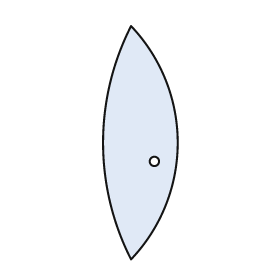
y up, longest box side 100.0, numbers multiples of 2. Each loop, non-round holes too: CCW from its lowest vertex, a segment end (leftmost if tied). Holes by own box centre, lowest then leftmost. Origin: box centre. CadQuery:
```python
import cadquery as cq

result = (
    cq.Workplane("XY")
    .moveTo(-4.0, -50.0)
    .threePointArc((16.0, 0.0), (-4.0, 50.0))
    .threePointArc((-16.0, 0.0), (-4.0, -50.0))
    .close()
    .moveTo(6.0, -8.0)
    .circle(2.0)
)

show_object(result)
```